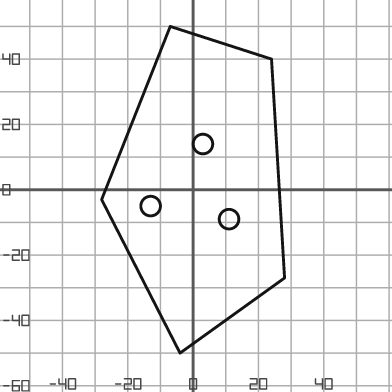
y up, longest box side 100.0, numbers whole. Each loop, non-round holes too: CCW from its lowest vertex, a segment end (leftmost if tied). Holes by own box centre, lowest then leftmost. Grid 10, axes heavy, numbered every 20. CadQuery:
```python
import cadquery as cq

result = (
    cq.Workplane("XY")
    .moveTo(-4.0, -50.0)
    .lineTo(28.0, -27.0)
    .lineTo(24.0, 40.0)
    .lineTo(-7.0, 50.0)
    .lineTo(-28.0, -3.0)
    .close()
    .moveTo(11.0, -9.0)
    .circle(3.0)
    .moveTo(-13.0, -5.0)
    .circle(3.0)
    .moveTo(3.0, 14.0)
    .circle(3.0)
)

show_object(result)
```